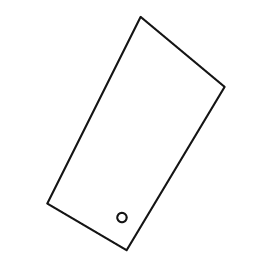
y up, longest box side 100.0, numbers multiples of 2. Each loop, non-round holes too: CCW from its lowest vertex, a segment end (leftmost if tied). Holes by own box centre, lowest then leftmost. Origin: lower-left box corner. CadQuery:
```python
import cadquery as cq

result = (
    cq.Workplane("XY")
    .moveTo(34.0, 0.0)
    .lineTo(76.0, 70.0)
    .lineTo(40.0, 100.0)
    .lineTo(0.0, 20.0)
    .close()
    .moveTo(32.0, 14.0)
    .circle(2.0)
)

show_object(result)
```